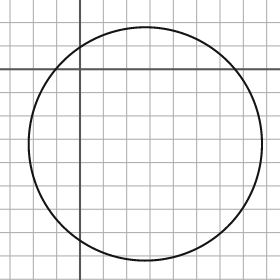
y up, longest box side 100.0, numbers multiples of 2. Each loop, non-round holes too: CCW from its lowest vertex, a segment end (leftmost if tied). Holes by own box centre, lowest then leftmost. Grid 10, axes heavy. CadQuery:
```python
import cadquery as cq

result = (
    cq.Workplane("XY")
    .moveTo(28.0, -32.0)
    .circle(50.0)
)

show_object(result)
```